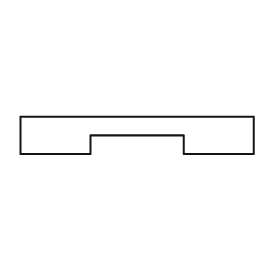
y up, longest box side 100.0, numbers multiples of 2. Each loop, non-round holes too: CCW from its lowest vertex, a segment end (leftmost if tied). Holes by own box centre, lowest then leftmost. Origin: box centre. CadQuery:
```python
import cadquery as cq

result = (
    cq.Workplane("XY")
    .moveTo(-50.0, -8.0)
    .lineTo(-20.0, -8.0)
    .lineTo(-20.0, 0.0)
    .lineTo(20.0, 0.0)
    .lineTo(20.0, -8.0)
    .lineTo(50.0, -8.0)
    .lineTo(50.0, 8.0)
    .lineTo(-50.0, 8.0)
    .close()
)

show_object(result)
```